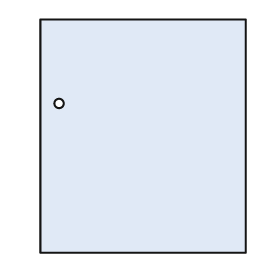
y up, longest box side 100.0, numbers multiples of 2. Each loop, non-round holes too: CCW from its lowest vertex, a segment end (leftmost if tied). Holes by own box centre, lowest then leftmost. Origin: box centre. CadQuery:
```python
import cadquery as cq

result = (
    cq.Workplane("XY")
    .moveTo(-44.0, -50.0)
    .lineTo(44.0, -50.0)
    .lineTo(44.0, 50.0)
    .lineTo(-44.0, 50.0)
    .close()
    .moveTo(-36.0, 14.0)
    .circle(2.0)
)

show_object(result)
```